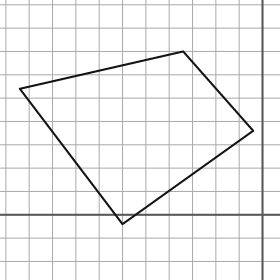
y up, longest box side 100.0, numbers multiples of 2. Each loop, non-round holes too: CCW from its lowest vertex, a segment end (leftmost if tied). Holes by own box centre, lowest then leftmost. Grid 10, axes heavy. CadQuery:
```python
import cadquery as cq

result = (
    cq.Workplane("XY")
    .moveTo(-60.0, -4.0)
    .lineTo(-4.0, 36.0)
    .lineTo(-34.0, 70.0)
    .lineTo(-104.0, 54.0)
    .close()
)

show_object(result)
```